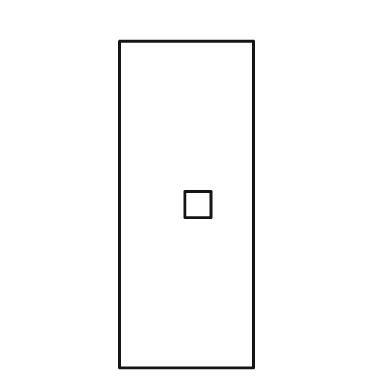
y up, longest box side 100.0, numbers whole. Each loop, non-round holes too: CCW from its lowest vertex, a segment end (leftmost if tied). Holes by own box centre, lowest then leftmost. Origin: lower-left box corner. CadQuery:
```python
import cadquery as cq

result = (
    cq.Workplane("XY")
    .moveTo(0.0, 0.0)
    .lineTo(41.0, 0.0)
    .lineTo(41.0, 100.0)
    .lineTo(0.0, 100.0)
    .close()
    .moveTo(20.0, 46.0)
    .lineTo(28.0, 46.0)
    .lineTo(28.0, 54.0)
    .lineTo(20.0, 54.0)
    .close()
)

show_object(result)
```